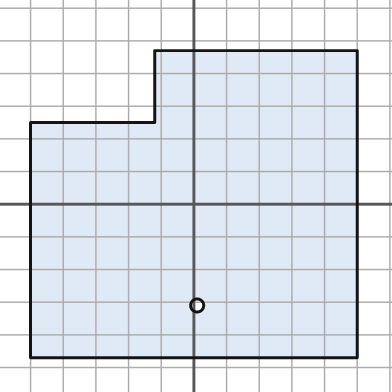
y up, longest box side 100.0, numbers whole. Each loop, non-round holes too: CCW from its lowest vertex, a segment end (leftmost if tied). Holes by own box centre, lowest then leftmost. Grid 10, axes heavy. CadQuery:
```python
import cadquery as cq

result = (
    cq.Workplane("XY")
    .moveTo(-50.0, -47.0)
    .lineTo(50.0, -47.0)
    .lineTo(50.0, 47.0)
    .lineTo(-12.0, 47.0)
    .lineTo(-12.0, 25.0)
    .lineTo(-50.0, 25.0)
    .close()
    .moveTo(1.0, -31.0)
    .circle(2.0)
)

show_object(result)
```